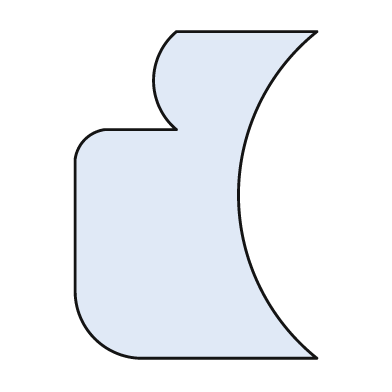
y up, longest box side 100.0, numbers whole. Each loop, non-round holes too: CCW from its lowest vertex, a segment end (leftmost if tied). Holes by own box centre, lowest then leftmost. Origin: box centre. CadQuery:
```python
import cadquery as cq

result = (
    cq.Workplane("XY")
    .moveTo(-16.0, -50.0)
    .lineTo(37.0, -50.0)
    .threePointArc((13.0, 0.0), (37.0, 50.0))
    .lineTo(-6.0, 50.0)
    .threePointArc((-13.0, 35.0), (-6.0, 20.0))
    .lineTo(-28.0, 20.0)
    .threePointArc((-34.0, 17.0), (-37.0, 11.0))
    .lineTo(-37.0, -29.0)
    .threePointArc((-31.0, -44.0), (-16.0, -50.0))
    .close()
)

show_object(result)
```